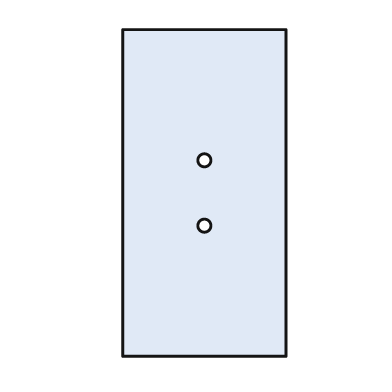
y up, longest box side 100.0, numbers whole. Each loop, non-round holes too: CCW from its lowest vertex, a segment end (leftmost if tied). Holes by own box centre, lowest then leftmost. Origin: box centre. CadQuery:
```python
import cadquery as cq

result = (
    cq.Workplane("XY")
    .moveTo(-25.0, -50.0)
    .lineTo(25.0, -50.0)
    .lineTo(25.0, 50.0)
    .lineTo(-25.0, 50.0)
    .close()
    .moveTo(0.0, -10.0)
    .circle(2.0)
    .moveTo(0.0, 10.0)
    .circle(2.0)
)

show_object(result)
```